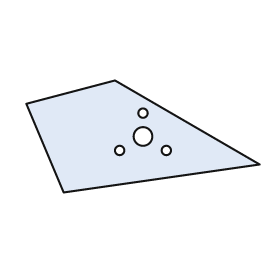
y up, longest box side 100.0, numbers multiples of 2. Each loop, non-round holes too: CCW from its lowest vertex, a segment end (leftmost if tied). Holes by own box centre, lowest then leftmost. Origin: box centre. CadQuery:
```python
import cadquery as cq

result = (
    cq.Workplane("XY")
    .moveTo(-34.0, -24.0)
    .lineTo(50.0, -12.0)
    .lineTo(-12.0, 24.0)
    .lineTo(-50.0, 14.0)
    .close()
    .moveTo(-10.0, -6.0)
    .circle(2.0)
    .moveTo(10.0, -6.0)
    .circle(2.0)
    .moveTo(0.0, 0.0)
    .circle(4.0)
    .moveTo(0.0, 10.0)
    .circle(2.0)
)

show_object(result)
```